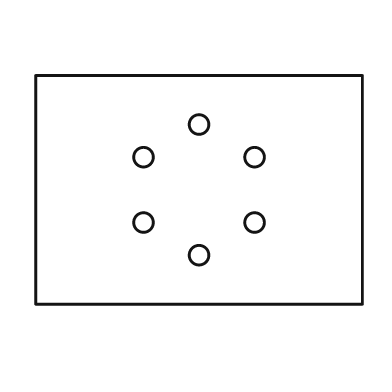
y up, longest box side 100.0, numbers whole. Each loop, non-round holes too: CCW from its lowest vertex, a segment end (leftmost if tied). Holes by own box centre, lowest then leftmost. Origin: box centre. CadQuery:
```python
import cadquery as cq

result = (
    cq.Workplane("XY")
    .moveTo(-50.0, -35.0)
    .lineTo(50.0, -35.0)
    .lineTo(50.0, 35.0)
    .lineTo(-50.0, 35.0)
    .close()
    .moveTo(0.0, -20.0)
    .circle(3.0)
    .moveTo(-17.0, -10.0)
    .circle(3.0)
    .moveTo(17.0, -10.0)
    .circle(3.0)
    .moveTo(-17.0, 10.0)
    .circle(3.0)
    .moveTo(17.0, 10.0)
    .circle(3.0)
    .moveTo(0.0, 20.0)
    .circle(3.0)
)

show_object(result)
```